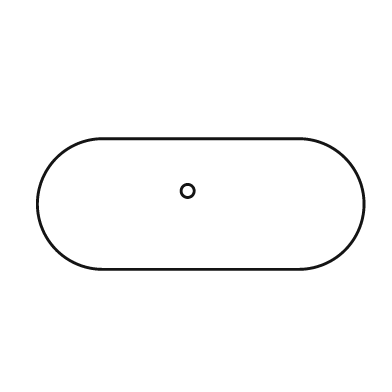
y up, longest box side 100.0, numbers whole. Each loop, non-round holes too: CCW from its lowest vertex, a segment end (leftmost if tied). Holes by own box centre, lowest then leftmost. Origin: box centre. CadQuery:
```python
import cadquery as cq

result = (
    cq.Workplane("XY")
    .moveTo(-30.0, -20.0)
    .lineTo(30.0, -20.0)
    .threePointArc((50.0, 0.0), (30.0, 20.0))
    .lineTo(-30.0, 20.0)
    .threePointArc((-50.0, 0.0), (-30.0, -20.0))
    .close()
    .moveTo(-4.0, 4.0)
    .circle(2.0)
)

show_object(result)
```